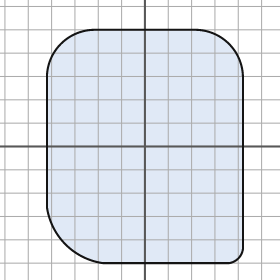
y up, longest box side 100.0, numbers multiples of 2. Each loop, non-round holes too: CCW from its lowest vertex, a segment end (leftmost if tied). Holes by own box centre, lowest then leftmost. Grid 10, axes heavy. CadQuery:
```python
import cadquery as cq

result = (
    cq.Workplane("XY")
    .moveTo(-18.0, -50.0)
    .lineTo(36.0, -50.0)
    .threePointArc((40.0, -48.0), (42.0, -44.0))
    .lineTo(42.0, 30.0)
    .threePointArc((36.0, 44.0), (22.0, 50.0))
    .lineTo(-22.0, 50.0)
    .threePointArc((-36.0, 44.0), (-42.0, 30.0))
    .lineTo(-42.0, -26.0)
    .threePointArc((-34.0, -42.0), (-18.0, -50.0))
    .close()
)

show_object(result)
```